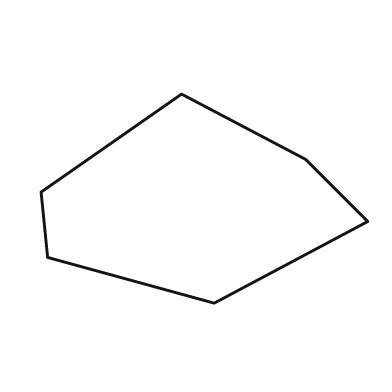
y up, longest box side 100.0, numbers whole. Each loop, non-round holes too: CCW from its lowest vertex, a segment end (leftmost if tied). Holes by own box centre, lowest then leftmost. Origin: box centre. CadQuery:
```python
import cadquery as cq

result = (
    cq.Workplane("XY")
    .moveTo(3.0, -32.0)
    .lineTo(50.0, -7.0)
    .lineTo(31.0, 12.0)
    .lineTo(-7.0, 32.0)
    .lineTo(-50.0, 2.0)
    .lineTo(-48.0, -18.0)
    .close()
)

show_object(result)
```